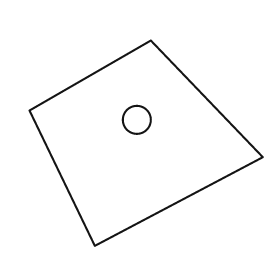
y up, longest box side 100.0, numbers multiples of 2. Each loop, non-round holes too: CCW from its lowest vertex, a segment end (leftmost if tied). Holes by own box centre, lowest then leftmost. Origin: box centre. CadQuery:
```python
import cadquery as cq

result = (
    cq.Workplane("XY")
    .moveTo(-22.0, -44.0)
    .lineTo(50.0, -6.0)
    .lineTo(2.0, 44.0)
    .lineTo(-50.0, 14.0)
    .close()
    .moveTo(-4.0, 10.0)
    .circle(6.0)
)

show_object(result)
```